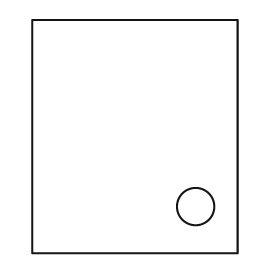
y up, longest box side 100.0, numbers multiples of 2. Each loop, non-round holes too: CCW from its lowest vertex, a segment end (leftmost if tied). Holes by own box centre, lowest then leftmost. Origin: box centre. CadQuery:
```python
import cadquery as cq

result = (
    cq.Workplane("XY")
    .moveTo(-44.0, -50.0)
    .lineTo(44.0, -50.0)
    .lineTo(44.0, 50.0)
    .lineTo(-44.0, 50.0)
    .close()
    .moveTo(26.0, -30.0)
    .circle(8.0)
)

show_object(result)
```